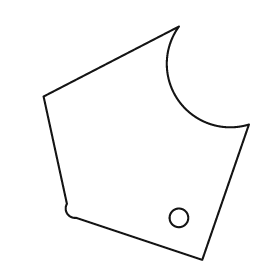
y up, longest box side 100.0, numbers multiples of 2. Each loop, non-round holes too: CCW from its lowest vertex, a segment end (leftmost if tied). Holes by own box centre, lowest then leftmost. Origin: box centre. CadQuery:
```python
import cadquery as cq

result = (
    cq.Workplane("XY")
    .moveTo(24.0, -50.0)
    .lineTo(44.0, 8.0)
    .threePointArc((14.0, 18.0), (14.0, 50.0))
    .lineTo(-44.0, 20.0)
    .lineTo(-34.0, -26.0)
    .threePointArc((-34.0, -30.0), (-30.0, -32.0))
    .close()
    .moveTo(14.0, -32.0)
    .circle(4.0)
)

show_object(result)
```